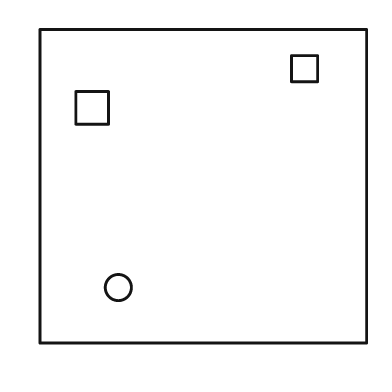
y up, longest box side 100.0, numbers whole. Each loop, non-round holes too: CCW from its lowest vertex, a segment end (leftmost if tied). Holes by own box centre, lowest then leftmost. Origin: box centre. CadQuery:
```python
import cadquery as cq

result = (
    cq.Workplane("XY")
    .moveTo(-50.0, -48.0)
    .lineTo(50.0, -48.0)
    .lineTo(50.0, 48.0)
    .lineTo(-50.0, 48.0)
    .close()
    .moveTo(-26.0, -31.0)
    .circle(4.0)
    .moveTo(-39.0, 19.0)
    .lineTo(-29.0, 19.0)
    .lineTo(-29.0, 29.0)
    .lineTo(-39.0, 29.0)
    .close()
    .moveTo(27.0, 32.0)
    .lineTo(35.0, 32.0)
    .lineTo(35.0, 40.0)
    .lineTo(27.0, 40.0)
    .close()
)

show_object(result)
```